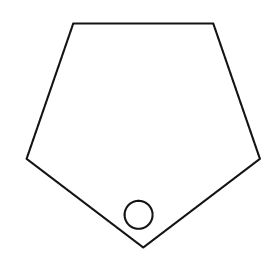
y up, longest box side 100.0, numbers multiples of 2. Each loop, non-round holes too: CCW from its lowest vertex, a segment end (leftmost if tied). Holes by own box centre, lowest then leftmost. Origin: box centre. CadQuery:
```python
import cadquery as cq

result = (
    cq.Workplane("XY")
    .moveTo(0.0, -48.0)
    .lineTo(50.0, -10.0)
    .lineTo(30.0, 48.0)
    .lineTo(-30.0, 48.0)
    .lineTo(-50.0, -10.0)
    .close()
    .moveTo(-2.0, -34.0)
    .circle(6.0)
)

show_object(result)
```